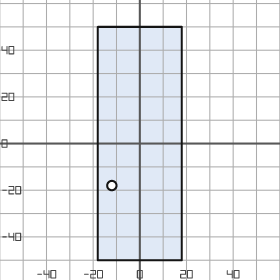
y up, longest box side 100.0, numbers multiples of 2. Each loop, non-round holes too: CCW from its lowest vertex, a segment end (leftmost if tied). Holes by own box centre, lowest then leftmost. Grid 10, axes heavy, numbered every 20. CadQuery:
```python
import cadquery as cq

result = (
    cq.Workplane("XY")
    .moveTo(-18.0, -50.0)
    .lineTo(18.0, -50.0)
    .lineTo(18.0, 50.0)
    .lineTo(-18.0, 50.0)
    .close()
    .moveTo(-12.0, -18.0)
    .circle(2.0)
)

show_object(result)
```